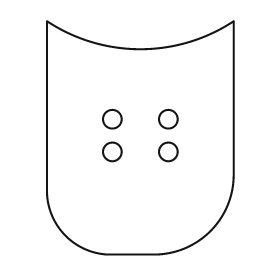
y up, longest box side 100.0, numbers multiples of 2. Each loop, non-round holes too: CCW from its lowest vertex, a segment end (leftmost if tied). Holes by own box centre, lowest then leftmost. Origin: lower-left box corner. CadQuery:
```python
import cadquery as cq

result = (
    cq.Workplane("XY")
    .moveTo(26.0, 0.0)
    .lineTo(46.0, 0.0)
    .threePointArc((70.0, 10.0), (80.0, 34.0))
    .lineTo(80.0, 100.0)
    .threePointArc((40.0, 88.0), (0.0, 100.0))
    .lineTo(0.0, 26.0)
    .threePointArc((8.0, 8.0), (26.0, 0.0))
    .close()
    .moveTo(28.0, 44.0)
    .circle(4.0)
    .moveTo(52.0, 44.0)
    .circle(4.0)
    .moveTo(28.0, 58.0)
    .circle(4.0)
    .moveTo(52.0, 58.0)
    .circle(4.0)
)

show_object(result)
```